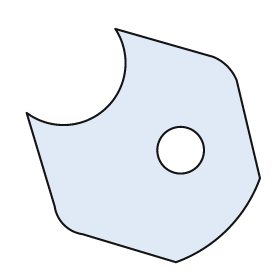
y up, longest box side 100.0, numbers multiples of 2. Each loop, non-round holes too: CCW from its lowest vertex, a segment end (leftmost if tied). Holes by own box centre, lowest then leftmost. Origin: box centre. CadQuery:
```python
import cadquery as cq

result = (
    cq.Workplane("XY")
    .moveTo(14.0, -50.0)
    .threePointArc((36.0, -36.0), (50.0, -14.0))
    .lineTo(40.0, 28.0)
    .threePointArc((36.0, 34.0), (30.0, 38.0))
    .lineTo(-12.0, 50.0)
    .threePointArc((-16.0, 16.0), (-50.0, 14.0))
    .lineTo(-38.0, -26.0)
    .threePointArc((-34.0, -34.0), (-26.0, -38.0))
    .close()
    .moveTo(16.0, -2.0)
    .circle(10.0)
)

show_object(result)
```